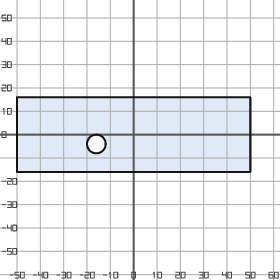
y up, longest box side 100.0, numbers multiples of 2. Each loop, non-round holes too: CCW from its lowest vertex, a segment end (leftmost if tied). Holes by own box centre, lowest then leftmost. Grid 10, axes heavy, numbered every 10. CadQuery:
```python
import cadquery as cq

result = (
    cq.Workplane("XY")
    .moveTo(-50.0, -16.0)
    .lineTo(50.0, -16.0)
    .lineTo(50.0, 16.0)
    .lineTo(-50.0, 16.0)
    .close()
    .moveTo(-16.0, -4.0)
    .circle(4.0)
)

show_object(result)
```